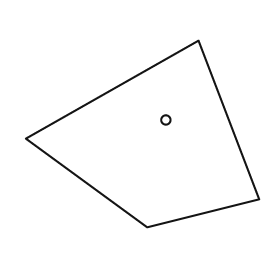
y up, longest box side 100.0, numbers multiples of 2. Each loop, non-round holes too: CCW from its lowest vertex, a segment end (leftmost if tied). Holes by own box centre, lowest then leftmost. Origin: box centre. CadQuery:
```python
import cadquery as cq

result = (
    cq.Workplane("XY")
    .moveTo(2.0, -40.0)
    .lineTo(50.0, -28.0)
    .lineTo(24.0, 40.0)
    .lineTo(-50.0, -2.0)
    .close()
    .moveTo(10.0, 6.0)
    .circle(2.0)
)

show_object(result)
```